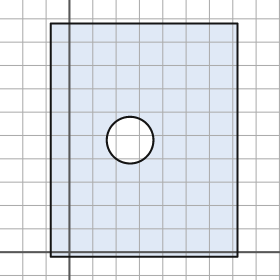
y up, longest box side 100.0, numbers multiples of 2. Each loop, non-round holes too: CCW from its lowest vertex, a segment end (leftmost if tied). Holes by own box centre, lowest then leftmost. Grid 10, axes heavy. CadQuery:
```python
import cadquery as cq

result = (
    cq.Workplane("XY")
    .moveTo(-8.0, -2.0)
    .lineTo(72.0, -2.0)
    .lineTo(72.0, 98.0)
    .lineTo(-8.0, 98.0)
    .close()
    .moveTo(26.0, 48.0)
    .circle(10.0)
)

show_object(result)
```